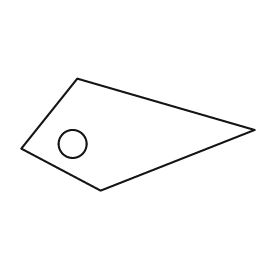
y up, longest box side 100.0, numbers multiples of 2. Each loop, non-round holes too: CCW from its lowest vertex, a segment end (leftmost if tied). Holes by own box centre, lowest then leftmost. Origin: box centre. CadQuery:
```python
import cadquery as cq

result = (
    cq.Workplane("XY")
    .moveTo(-16.0, -24.0)
    .lineTo(50.0, 2.0)
    .lineTo(-26.0, 24.0)
    .lineTo(-50.0, -6.0)
    .close()
    .moveTo(-28.0, -4.0)
    .circle(6.0)
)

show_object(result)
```